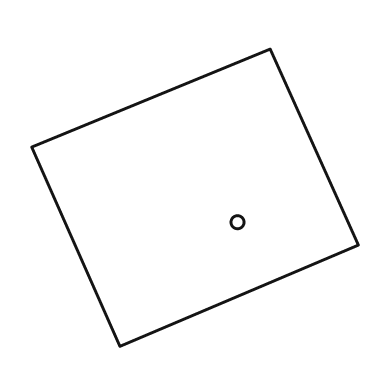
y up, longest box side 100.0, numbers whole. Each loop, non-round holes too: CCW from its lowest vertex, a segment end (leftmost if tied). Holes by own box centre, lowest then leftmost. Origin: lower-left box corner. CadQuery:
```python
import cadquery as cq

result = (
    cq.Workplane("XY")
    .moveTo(27.0, 0.0)
    .lineTo(100.0, 31.0)
    .lineTo(73.0, 91.0)
    .lineTo(0.0, 61.0)
    .close()
    .moveTo(63.0, 38.0)
    .circle(2.0)
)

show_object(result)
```